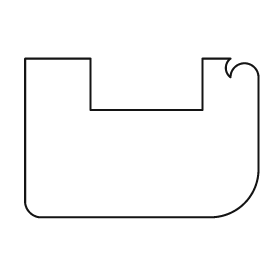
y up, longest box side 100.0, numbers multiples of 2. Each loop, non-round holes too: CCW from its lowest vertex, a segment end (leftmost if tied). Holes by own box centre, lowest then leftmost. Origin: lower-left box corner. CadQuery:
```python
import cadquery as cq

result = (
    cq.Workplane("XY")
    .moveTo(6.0, 0.0)
    .lineTo(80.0, 0.0)
    .threePointArc((94.0, 6.0), (100.0, 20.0))
    .lineTo(100.0, 60.0)
    .threePointArc((94.0, 66.0), (88.0, 60.0))
    .threePointArc((86.0, 64.0), (88.0, 68.0))
    .lineTo(76.0, 68.0)
    .lineTo(76.0, 46.0)
    .lineTo(28.0, 46.0)
    .lineTo(28.0, 68.0)
    .lineTo(0.0, 68.0)
    .lineTo(0.0, 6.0)
    .threePointArc((2.0, 2.0), (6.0, 0.0))
    .close()
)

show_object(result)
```